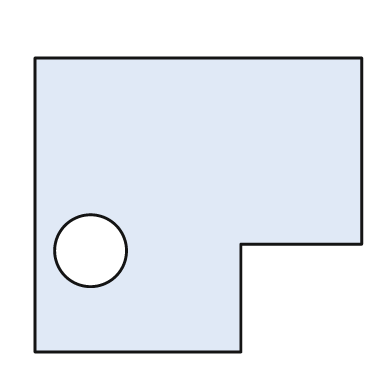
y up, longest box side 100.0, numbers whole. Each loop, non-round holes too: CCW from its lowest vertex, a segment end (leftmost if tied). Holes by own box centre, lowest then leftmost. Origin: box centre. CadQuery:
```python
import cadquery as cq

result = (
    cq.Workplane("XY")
    .moveTo(-50.0, -45.0)
    .lineTo(13.0, -45.0)
    .lineTo(13.0, -12.0)
    .lineTo(50.0, -12.0)
    .lineTo(50.0, 45.0)
    .lineTo(-50.0, 45.0)
    .close()
    .moveTo(-33.0, -14.0)
    .circle(11.0)
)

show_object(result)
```